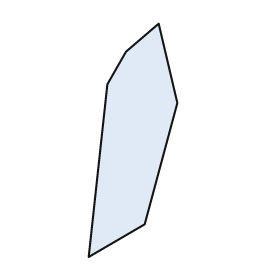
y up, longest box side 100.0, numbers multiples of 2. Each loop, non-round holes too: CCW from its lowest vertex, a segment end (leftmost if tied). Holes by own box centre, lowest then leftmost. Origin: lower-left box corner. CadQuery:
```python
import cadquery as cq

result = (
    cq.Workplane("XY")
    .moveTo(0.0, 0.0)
    .lineTo(24.0, 14.0)
    .lineTo(38.0, 66.0)
    .lineTo(30.0, 100.0)
    .lineTo(16.0, 88.0)
    .lineTo(8.0, 74.0)
    .close()
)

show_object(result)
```